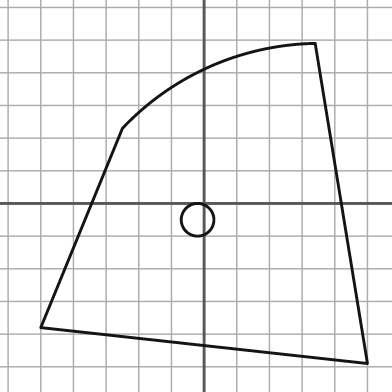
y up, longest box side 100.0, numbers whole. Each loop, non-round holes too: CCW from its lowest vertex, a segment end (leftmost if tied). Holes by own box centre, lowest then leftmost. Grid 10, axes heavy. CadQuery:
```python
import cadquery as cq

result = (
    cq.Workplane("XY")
    .moveTo(50.0, -49.0)
    .lineTo(34.0, 49.0)
    .threePointArc((2.0, 42.0), (-25.0, 23.0))
    .lineTo(-50.0, -38.0)
    .close()
    .moveTo(-2.0, -5.0)
    .circle(5.0)
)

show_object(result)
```